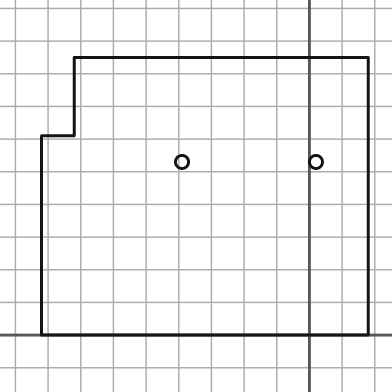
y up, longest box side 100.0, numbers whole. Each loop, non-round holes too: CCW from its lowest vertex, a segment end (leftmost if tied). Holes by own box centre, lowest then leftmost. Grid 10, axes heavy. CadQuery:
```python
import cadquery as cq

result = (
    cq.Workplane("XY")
    .moveTo(-82.0, 0.0)
    .lineTo(18.0, 0.0)
    .lineTo(18.0, 85.0)
    .lineTo(-72.0, 85.0)
    .lineTo(-72.0, 61.0)
    .lineTo(-82.0, 61.0)
    .close()
    .moveTo(-39.0, 53.0)
    .circle(2.0)
    .moveTo(2.0, 53.0)
    .circle(2.0)
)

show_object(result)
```